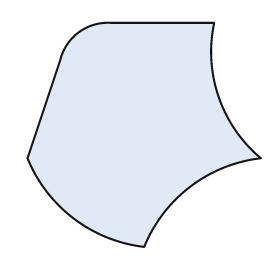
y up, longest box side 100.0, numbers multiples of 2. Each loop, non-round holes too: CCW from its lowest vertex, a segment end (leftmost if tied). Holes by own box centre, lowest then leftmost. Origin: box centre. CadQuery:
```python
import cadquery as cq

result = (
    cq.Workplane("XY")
    .moveTo(0.0, -48.0)
    .threePointArc((20.0, -22.0), (50.0, -10.0))
    .threePointArc((32.0, 16.0), (30.0, 48.0))
    .lineTo(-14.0, 48.0)
    .threePointArc((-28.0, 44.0), (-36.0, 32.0))
    .lineTo(-50.0, -10.0)
    .threePointArc((-30.0, -36.0), (0.0, -48.0))
    .close()
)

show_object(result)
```